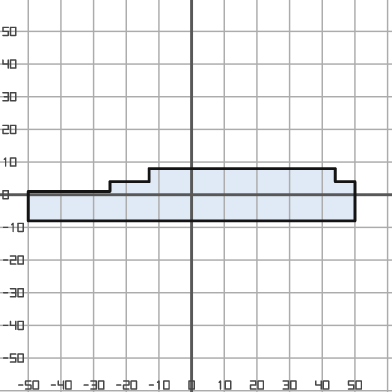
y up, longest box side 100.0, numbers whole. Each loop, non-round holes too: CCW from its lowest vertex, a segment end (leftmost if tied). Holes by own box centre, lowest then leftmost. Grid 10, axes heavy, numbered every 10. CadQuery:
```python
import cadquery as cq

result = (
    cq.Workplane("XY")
    .moveTo(-50.0, -8.0)
    .lineTo(50.0, -8.0)
    .lineTo(50.0, 4.0)
    .lineTo(44.0, 4.0)
    .lineTo(44.0, 8.0)
    .lineTo(-13.0, 8.0)
    .lineTo(-13.0, 4.0)
    .lineTo(-25.0, 4.0)
    .lineTo(-25.0, 1.0)
    .lineTo(-50.0, 1.0)
    .close()
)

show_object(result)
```